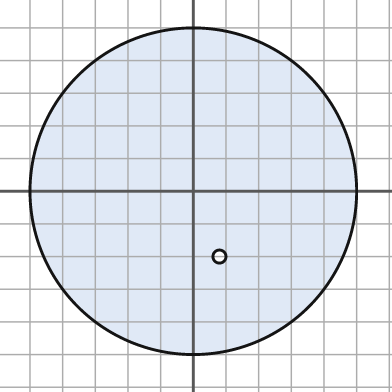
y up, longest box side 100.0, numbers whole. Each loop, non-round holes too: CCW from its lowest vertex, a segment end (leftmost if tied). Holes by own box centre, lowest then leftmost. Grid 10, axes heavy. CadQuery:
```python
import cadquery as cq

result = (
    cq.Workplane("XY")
    .moveTo(0.0, 0.0)
    .circle(50.0)
    .moveTo(8.0, -20.0)
    .circle(2.0)
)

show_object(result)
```